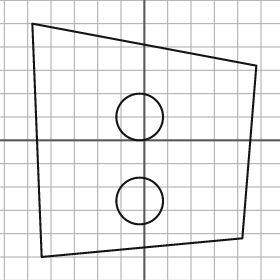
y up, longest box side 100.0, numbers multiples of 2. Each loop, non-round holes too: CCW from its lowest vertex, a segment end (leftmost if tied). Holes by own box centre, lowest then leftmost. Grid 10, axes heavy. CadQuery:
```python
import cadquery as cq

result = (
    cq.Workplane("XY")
    .moveTo(-44.0, -50.0)
    .lineTo(42.0, -42.0)
    .lineTo(48.0, 32.0)
    .lineTo(-48.0, 50.0)
    .close()
    .moveTo(-2.0, -26.0)
    .circle(10.0)
    .moveTo(-2.0, 10.0)
    .circle(10.0)
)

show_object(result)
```